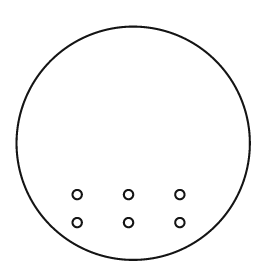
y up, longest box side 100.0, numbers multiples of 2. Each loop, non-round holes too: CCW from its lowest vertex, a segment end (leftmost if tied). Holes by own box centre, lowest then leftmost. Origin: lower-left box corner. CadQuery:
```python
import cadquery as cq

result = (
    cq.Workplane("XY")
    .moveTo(50.0, 50.0)
    .circle(50.0)
    .moveTo(26.0, 16.0)
    .circle(2.0)
    .moveTo(48.0, 16.0)
    .circle(2.0)
    .moveTo(70.0, 16.0)
    .circle(2.0)
    .moveTo(26.0, 28.0)
    .circle(2.0)
    .moveTo(48.0, 28.0)
    .circle(2.0)
    .moveTo(70.0, 28.0)
    .circle(2.0)
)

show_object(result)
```